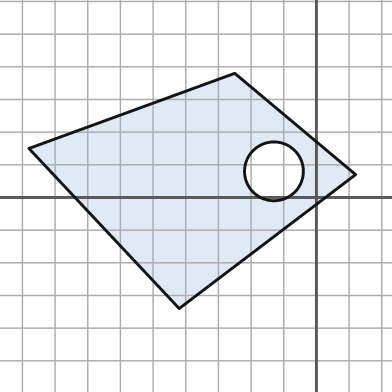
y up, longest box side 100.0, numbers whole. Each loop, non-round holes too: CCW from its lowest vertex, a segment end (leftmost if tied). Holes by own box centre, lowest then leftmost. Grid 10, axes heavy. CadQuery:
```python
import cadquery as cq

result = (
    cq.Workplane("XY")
    .moveTo(-42.0, -34.0)
    .lineTo(12.0, 7.0)
    .lineTo(-25.0, 38.0)
    .lineTo(-88.0, 15.0)
    .close()
    .moveTo(-13.0, 8.0)
    .circle(9.0)
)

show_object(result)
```